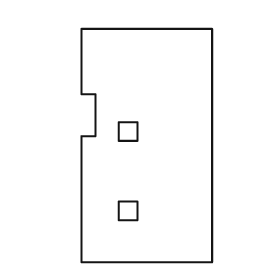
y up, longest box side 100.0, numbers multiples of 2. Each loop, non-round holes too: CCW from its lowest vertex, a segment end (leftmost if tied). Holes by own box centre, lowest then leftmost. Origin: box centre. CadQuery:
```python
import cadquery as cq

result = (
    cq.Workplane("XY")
    .moveTo(-28.0, -50.0)
    .lineTo(28.0, -50.0)
    .lineTo(28.0, 50.0)
    .lineTo(-28.0, 50.0)
    .lineTo(-28.0, 22.0)
    .lineTo(-22.0, 22.0)
    .lineTo(-22.0, 4.0)
    .lineTo(-28.0, 4.0)
    .close()
    .moveTo(-12.0, -32.0)
    .lineTo(-4.0, -32.0)
    .lineTo(-4.0, -24.0)
    .lineTo(-12.0, -24.0)
    .close()
    .moveTo(-12.0, 2.0)
    .lineTo(-4.0, 2.0)
    .lineTo(-4.0, 10.0)
    .lineTo(-12.0, 10.0)
    .close()
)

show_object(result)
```